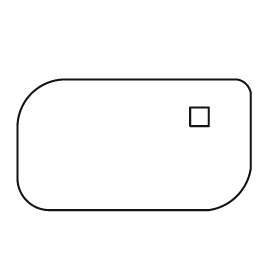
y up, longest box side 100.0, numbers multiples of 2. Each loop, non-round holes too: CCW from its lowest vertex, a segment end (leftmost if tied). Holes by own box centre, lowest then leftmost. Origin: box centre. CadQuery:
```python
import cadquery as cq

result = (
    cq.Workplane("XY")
    .moveTo(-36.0, -28.0)
    .lineTo(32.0, -28.0)
    .threePointArc((44.0, -22.0), (50.0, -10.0))
    .lineTo(50.0, 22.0)
    .threePointArc((48.0, 26.0), (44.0, 28.0))
    .lineTo(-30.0, 28.0)
    .threePointArc((-44.0, 22.0), (-50.0, 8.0))
    .lineTo(-50.0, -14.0)
    .threePointArc((-46.0, -24.0), (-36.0, -28.0))
    .close()
    .moveTo(24.0, 8.0)
    .lineTo(32.0, 8.0)
    .lineTo(32.0, 16.0)
    .lineTo(24.0, 16.0)
    .close()
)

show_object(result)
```